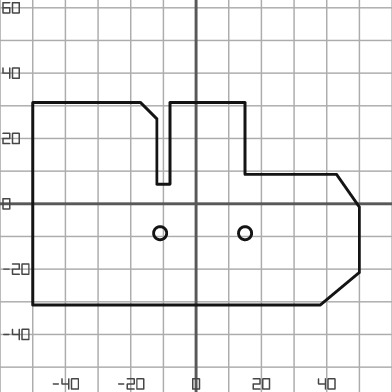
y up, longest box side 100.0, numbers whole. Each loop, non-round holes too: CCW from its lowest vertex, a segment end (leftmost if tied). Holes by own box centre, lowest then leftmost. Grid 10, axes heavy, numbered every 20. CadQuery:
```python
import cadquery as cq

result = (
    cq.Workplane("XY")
    .moveTo(-50.0, -31.0)
    .lineTo(38.0, -31.0)
    .lineTo(50.0, -21.0)
    .lineTo(50.0, -1.0)
    .lineTo(43.0, 9.0)
    .lineTo(15.0, 9.0)
    .lineTo(15.0, 31.0)
    .lineTo(-8.0, 31.0)
    .lineTo(-8.0, 6.0)
    .lineTo(-12.0, 6.0)
    .lineTo(-12.0, 26.0)
    .lineTo(-17.0, 31.0)
    .lineTo(-50.0, 31.0)
    .close()
    .moveTo(-11.0, -9.0)
    .circle(2.0)
    .moveTo(15.0, -9.0)
    .circle(2.0)
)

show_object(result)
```